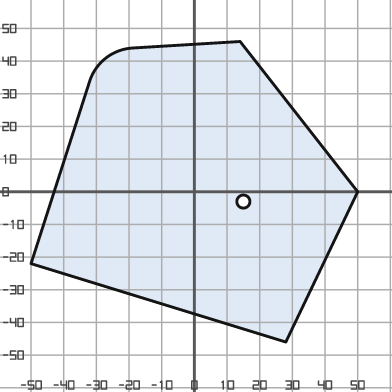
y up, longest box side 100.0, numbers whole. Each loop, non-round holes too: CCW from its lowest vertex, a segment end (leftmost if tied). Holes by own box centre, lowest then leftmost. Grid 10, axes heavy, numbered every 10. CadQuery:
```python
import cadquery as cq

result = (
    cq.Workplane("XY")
    .moveTo(28.0, -46.0)
    .lineTo(50.0, 0.0)
    .lineTo(14.0, 46.0)
    .lineTo(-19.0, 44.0)
    .threePointArc((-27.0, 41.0), (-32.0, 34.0))
    .lineTo(-50.0, -22.0)
    .close()
    .moveTo(15.0, -3.0)
    .circle(2.0)
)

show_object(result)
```